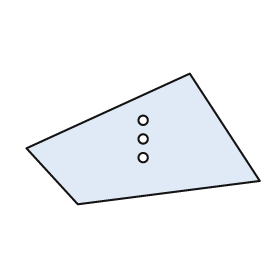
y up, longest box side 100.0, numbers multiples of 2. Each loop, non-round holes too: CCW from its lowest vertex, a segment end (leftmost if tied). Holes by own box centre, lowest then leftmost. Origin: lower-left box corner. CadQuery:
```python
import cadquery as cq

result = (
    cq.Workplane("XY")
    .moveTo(22.0, 0.0)
    .lineTo(100.0, 10.0)
    .lineTo(70.0, 56.0)
    .lineTo(0.0, 24.0)
    .close()
    .moveTo(50.0, 20.0)
    .circle(2.0)
    .moveTo(50.0, 28.0)
    .circle(2.0)
    .moveTo(50.0, 36.0)
    .circle(2.0)
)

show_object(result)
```